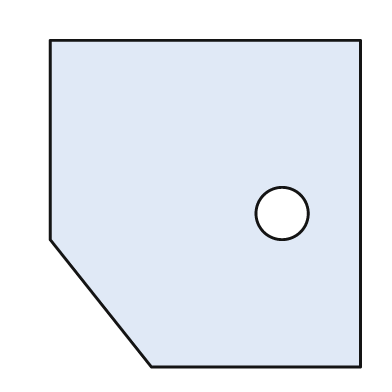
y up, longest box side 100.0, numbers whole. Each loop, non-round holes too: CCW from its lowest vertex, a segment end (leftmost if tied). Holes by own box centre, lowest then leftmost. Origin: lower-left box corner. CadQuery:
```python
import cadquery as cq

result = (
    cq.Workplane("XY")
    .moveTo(31.0, 0.0)
    .lineTo(95.0, 0.0)
    .lineTo(95.0, 100.0)
    .lineTo(0.0, 100.0)
    .lineTo(0.0, 39.0)
    .close()
    .moveTo(71.0, 47.0)
    .circle(8.0)
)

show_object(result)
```